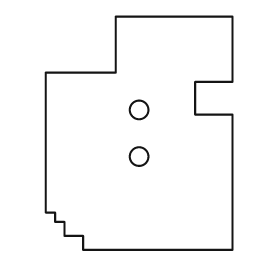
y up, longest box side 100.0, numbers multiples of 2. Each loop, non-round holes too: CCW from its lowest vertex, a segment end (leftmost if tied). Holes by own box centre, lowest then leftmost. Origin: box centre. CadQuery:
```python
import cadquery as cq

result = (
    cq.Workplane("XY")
    .moveTo(-24.0, -50.0)
    .lineTo(40.0, -50.0)
    .lineTo(40.0, 8.0)
    .lineTo(24.0, 8.0)
    .lineTo(24.0, 22.0)
    .lineTo(40.0, 22.0)
    .lineTo(40.0, 50.0)
    .lineTo(-10.0, 50.0)
    .lineTo(-10.0, 26.0)
    .lineTo(-40.0, 26.0)
    .lineTo(-40.0, -34.0)
    .lineTo(-36.0, -34.0)
    .lineTo(-36.0, -38.0)
    .lineTo(-32.0, -38.0)
    .lineTo(-32.0, -44.0)
    .lineTo(-24.0, -44.0)
    .close()
    .moveTo(0.0, -10.0)
    .circle(4.0)
    .moveTo(0.0, 10.0)
    .circle(4.0)
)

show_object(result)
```